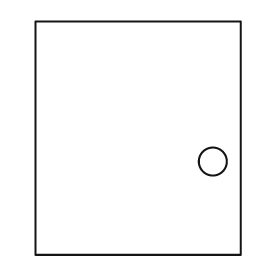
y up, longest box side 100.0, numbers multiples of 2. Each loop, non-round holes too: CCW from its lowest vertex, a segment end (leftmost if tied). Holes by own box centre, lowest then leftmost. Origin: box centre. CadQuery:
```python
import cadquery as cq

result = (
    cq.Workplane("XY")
    .moveTo(-44.0, -50.0)
    .lineTo(44.0, -50.0)
    .lineTo(44.0, 50.0)
    .lineTo(-44.0, 50.0)
    .close()
    .moveTo(32.0, -10.0)
    .circle(6.0)
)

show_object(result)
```